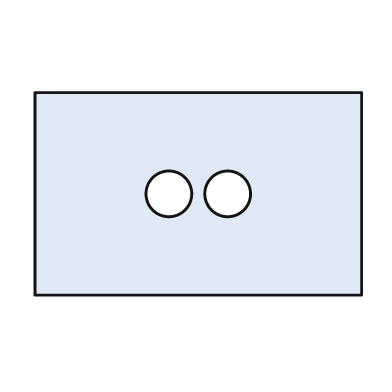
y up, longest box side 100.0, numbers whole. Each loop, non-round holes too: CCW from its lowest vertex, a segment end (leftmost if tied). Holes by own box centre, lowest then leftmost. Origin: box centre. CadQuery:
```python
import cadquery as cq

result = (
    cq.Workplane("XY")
    .moveTo(-50.0, -31.0)
    .lineTo(50.0, -31.0)
    .lineTo(50.0, 31.0)
    .lineTo(-50.0, 31.0)
    .close()
    .moveTo(-9.0, 0.0)
    .circle(7.0)
    .moveTo(9.0, 0.0)
    .circle(7.0)
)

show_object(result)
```